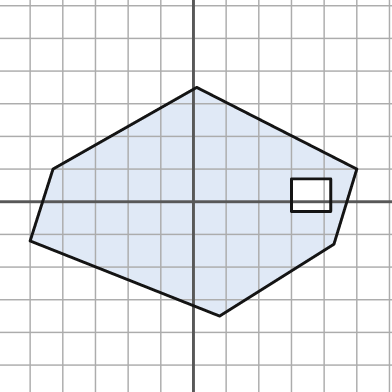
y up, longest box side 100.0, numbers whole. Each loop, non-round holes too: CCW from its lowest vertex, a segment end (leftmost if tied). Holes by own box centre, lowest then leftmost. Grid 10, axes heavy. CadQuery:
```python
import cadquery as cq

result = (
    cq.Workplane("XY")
    .moveTo(8.0, -35.0)
    .lineTo(43.0, -13.0)
    .lineTo(50.0, 10.0)
    .lineTo(1.0, 35.0)
    .lineTo(-43.0, 10.0)
    .lineTo(-50.0, -12.0)
    .close()
    .moveTo(30.0, -3.0)
    .lineTo(42.0, -3.0)
    .lineTo(42.0, 7.0)
    .lineTo(30.0, 7.0)
    .close()
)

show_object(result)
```